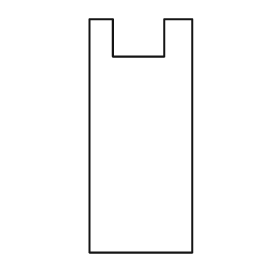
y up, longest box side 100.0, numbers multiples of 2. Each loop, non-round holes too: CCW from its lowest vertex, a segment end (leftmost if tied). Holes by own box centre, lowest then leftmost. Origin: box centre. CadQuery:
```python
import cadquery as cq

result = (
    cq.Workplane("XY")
    .moveTo(-22.0, -50.0)
    .lineTo(22.0, -50.0)
    .lineTo(22.0, 50.0)
    .lineTo(10.0, 50.0)
    .lineTo(10.0, 34.0)
    .lineTo(-12.0, 34.0)
    .lineTo(-12.0, 50.0)
    .lineTo(-22.0, 50.0)
    .close()
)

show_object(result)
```